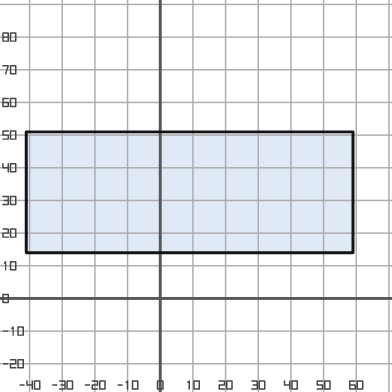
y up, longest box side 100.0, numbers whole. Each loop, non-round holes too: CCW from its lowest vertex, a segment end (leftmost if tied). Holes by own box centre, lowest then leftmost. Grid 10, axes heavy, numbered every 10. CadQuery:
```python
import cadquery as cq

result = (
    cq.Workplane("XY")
    .moveTo(-41.0, 14.0)
    .lineTo(59.0, 14.0)
    .lineTo(59.0, 51.0)
    .lineTo(-41.0, 51.0)
    .close()
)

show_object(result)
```